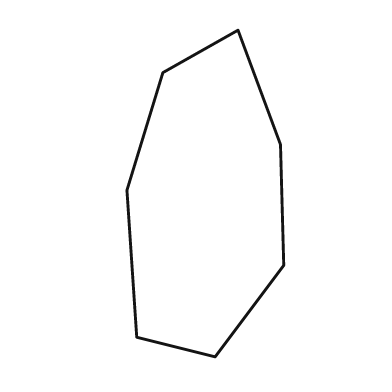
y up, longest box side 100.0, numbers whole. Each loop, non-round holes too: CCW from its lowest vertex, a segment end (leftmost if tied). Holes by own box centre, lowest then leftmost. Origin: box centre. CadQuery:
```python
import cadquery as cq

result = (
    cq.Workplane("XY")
    .moveTo(3.0, -50.0)
    .lineTo(24.0, -22.0)
    .lineTo(23.0, 15.0)
    .lineTo(10.0, 50.0)
    .lineTo(-13.0, 37.0)
    .lineTo(-24.0, 1.0)
    .lineTo(-21.0, -44.0)
    .close()
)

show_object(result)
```